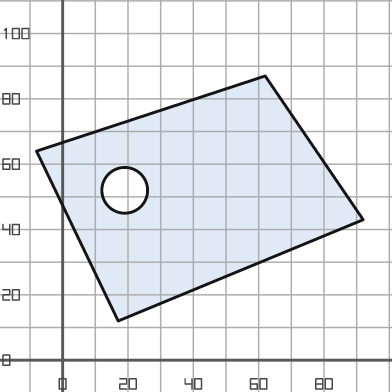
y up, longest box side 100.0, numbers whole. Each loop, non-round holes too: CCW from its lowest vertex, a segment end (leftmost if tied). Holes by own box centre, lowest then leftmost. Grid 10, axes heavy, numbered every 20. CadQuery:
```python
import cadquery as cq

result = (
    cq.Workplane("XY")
    .moveTo(17.0, 12.0)
    .lineTo(92.0, 43.0)
    .lineTo(62.0, 87.0)
    .lineTo(-8.0, 64.0)
    .close()
    .moveTo(19.0, 52.0)
    .circle(7.0)
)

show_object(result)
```